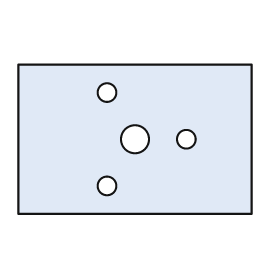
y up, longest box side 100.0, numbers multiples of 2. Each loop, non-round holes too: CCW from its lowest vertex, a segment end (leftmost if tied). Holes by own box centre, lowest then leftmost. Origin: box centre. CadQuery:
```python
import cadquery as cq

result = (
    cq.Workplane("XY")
    .moveTo(-50.0, -32.0)
    .lineTo(50.0, -32.0)
    .lineTo(50.0, 32.0)
    .lineTo(-50.0, 32.0)
    .close()
    .moveTo(-12.0, -20.0)
    .circle(4.0)
    .moveTo(0.0, 0.0)
    .circle(6.0)
    .moveTo(22.0, 0.0)
    .circle(4.0)
    .moveTo(-12.0, 20.0)
    .circle(4.0)
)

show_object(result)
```